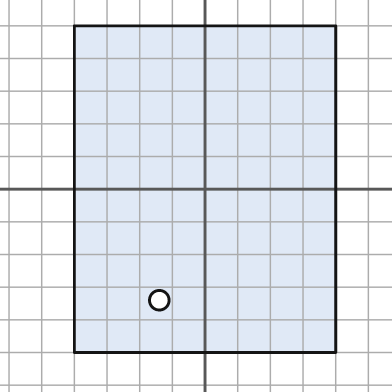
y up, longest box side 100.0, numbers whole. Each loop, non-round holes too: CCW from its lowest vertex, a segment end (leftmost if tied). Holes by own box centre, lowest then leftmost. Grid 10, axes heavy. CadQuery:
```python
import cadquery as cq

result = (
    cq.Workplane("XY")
    .moveTo(-40.0, -50.0)
    .lineTo(40.0, -50.0)
    .lineTo(40.0, 50.0)
    .lineTo(-40.0, 50.0)
    .close()
    .moveTo(-14.0, -34.0)
    .circle(3.0)
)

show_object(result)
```